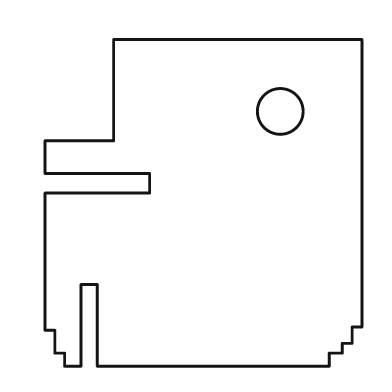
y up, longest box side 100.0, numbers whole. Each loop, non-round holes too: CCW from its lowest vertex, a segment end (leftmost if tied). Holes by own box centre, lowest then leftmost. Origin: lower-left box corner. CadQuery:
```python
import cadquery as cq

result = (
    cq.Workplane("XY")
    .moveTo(6.0, 0.0)
    .lineTo(11.0, 0.0)
    .lineTo(11.0, 25.0)
    .lineTo(16.0, 25.0)
    .lineTo(16.0, 0.0)
    .lineTo(87.0, 0.0)
    .lineTo(87.0, 4.0)
    .lineTo(91.0, 4.0)
    .lineTo(91.0, 7.0)
    .lineTo(94.0, 7.0)
    .lineTo(94.0, 12.0)
    .lineTo(97.0, 12.0)
    .lineTo(97.0, 100.0)
    .lineTo(21.0, 100.0)
    .lineTo(21.0, 69.0)
    .lineTo(0.0, 69.0)
    .lineTo(0.0, 59.0)
    .lineTo(32.0, 59.0)
    .lineTo(32.0, 53.0)
    .lineTo(0.0, 53.0)
    .lineTo(0.0, 11.0)
    .lineTo(3.0, 11.0)
    .lineTo(3.0, 4.0)
    .lineTo(6.0, 4.0)
    .close()
    .moveTo(72.0, 78.0)
    .circle(7.0)
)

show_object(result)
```